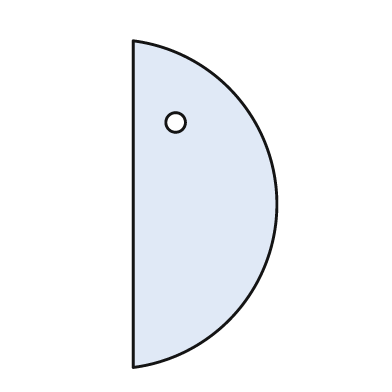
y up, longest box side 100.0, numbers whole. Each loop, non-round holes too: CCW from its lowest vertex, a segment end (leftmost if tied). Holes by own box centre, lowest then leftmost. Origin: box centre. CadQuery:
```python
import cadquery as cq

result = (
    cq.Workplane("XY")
    .moveTo(-22.0, -50.0)
    .threePointArc((22.0, 0.0), (-22.0, 50.0))
    .close()
    .moveTo(-9.0, 25.0)
    .circle(3.0)
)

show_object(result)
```